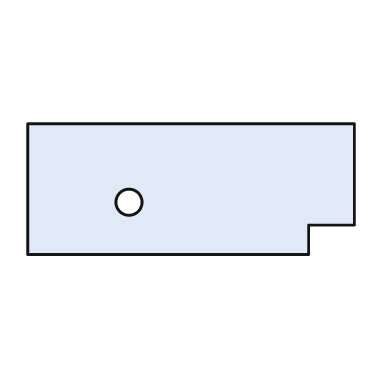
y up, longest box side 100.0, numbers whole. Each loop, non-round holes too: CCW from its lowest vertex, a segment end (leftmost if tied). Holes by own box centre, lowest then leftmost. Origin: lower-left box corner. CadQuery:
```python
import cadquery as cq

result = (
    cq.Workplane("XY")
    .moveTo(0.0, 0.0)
    .lineTo(86.0, 0.0)
    .lineTo(86.0, 9.0)
    .lineTo(100.0, 9.0)
    .lineTo(100.0, 40.0)
    .lineTo(0.0, 40.0)
    .close()
    .moveTo(31.0, 16.0)
    .circle(4.0)
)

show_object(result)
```